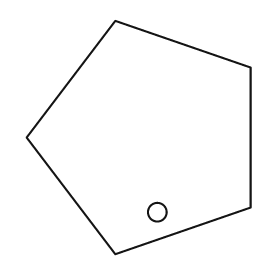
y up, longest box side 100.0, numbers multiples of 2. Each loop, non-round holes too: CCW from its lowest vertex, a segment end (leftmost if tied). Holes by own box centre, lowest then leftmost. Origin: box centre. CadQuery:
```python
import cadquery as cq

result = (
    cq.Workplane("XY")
    .moveTo(-10.0, -50.0)
    .lineTo(48.0, -30.0)
    .lineTo(48.0, 30.0)
    .lineTo(-10.0, 50.0)
    .lineTo(-48.0, 0.0)
    .close()
    .moveTo(8.0, -32.0)
    .circle(4.0)
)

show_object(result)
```